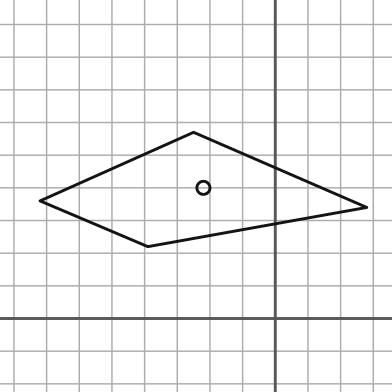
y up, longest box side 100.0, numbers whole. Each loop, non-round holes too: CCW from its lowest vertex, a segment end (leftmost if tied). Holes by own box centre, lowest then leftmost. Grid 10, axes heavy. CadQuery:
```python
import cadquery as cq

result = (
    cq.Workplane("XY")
    .moveTo(-39.0, 22.0)
    .lineTo(28.0, 34.0)
    .lineTo(-25.0, 57.0)
    .lineTo(-72.0, 36.0)
    .close()
    .moveTo(-22.0, 40.0)
    .circle(2.0)
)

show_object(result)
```